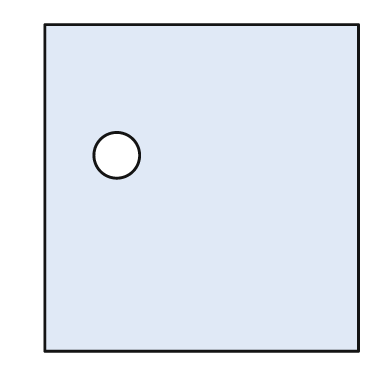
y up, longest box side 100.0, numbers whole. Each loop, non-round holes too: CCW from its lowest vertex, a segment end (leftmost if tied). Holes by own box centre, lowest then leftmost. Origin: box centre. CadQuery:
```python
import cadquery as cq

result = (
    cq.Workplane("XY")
    .moveTo(-48.0, -50.0)
    .lineTo(48.0, -50.0)
    .lineTo(48.0, 50.0)
    .lineTo(-48.0, 50.0)
    .close()
    .moveTo(-26.0, 10.0)
    .circle(7.0)
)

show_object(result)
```